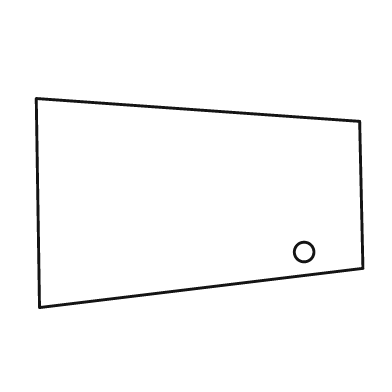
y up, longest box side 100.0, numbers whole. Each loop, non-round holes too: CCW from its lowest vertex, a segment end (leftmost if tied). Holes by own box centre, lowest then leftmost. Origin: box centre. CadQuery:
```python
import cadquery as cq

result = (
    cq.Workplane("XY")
    .moveTo(-49.0, -32.0)
    .lineTo(50.0, -20.0)
    .lineTo(49.0, 25.0)
    .lineTo(-50.0, 32.0)
    .close()
    .moveTo(32.0, -15.0)
    .circle(3.0)
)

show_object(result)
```